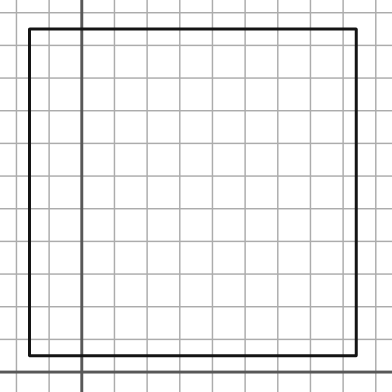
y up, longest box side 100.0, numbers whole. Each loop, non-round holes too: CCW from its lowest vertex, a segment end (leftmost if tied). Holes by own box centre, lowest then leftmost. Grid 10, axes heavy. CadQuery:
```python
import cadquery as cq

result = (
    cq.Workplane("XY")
    .moveTo(-16.0, 5.0)
    .lineTo(84.0, 5.0)
    .lineTo(84.0, 105.0)
    .lineTo(-16.0, 105.0)
    .close()
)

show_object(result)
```